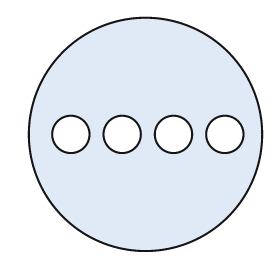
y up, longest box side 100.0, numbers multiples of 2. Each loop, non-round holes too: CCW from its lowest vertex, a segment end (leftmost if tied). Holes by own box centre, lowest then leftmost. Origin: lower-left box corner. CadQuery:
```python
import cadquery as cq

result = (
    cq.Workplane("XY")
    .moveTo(50.0, 50.0)
    .circle(50.0)
    .moveTo(18.0, 50.0)
    .circle(8.0)
    .moveTo(40.0, 50.0)
    .circle(8.0)
    .moveTo(62.0, 50.0)
    .circle(8.0)
    .moveTo(84.0, 50.0)
    .circle(8.0)
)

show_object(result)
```